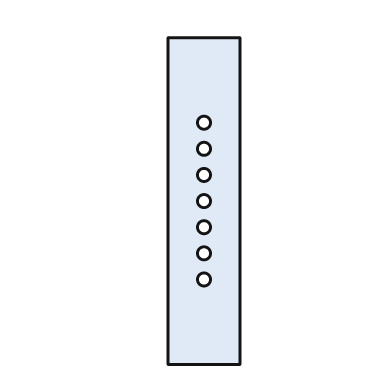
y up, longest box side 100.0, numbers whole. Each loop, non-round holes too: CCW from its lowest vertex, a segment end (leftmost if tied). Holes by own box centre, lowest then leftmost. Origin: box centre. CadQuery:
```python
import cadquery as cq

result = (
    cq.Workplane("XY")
    .moveTo(-11.0, -50.0)
    .lineTo(11.0, -50.0)
    .lineTo(11.0, 50.0)
    .lineTo(-11.0, 50.0)
    .close()
    .moveTo(0.0, -24.0)
    .circle(2.0)
    .moveTo(0.0, -16.0)
    .circle(2.0)
    .moveTo(0.0, -8.0)
    .circle(2.0)
    .moveTo(0.0, 0.0)
    .circle(2.0)
    .moveTo(0.0, 8.0)
    .circle(2.0)
    .moveTo(0.0, 16.0)
    .circle(2.0)
    .moveTo(0.0, 24.0)
    .circle(2.0)
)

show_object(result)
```